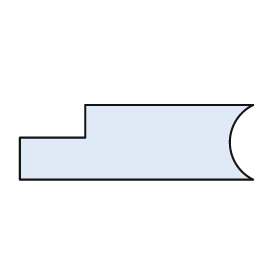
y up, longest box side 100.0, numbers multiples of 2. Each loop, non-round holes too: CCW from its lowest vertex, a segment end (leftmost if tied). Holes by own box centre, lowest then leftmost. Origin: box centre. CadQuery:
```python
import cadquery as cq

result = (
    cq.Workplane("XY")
    .moveTo(-50.0, -16.0)
    .lineTo(50.0, -16.0)
    .threePointArc((40.0, 0.0), (50.0, 16.0))
    .lineTo(-22.0, 16.0)
    .lineTo(-22.0, 2.0)
    .lineTo(-50.0, 2.0)
    .close()
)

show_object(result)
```